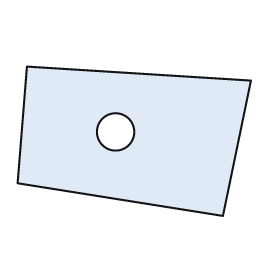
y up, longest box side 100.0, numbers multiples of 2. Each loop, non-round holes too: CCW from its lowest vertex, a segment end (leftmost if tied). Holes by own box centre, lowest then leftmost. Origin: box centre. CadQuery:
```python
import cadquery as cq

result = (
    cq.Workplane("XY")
    .moveTo(38.0, -32.0)
    .lineTo(50.0, 26.0)
    .lineTo(-46.0, 32.0)
    .lineTo(-50.0, -18.0)
    .close()
    .moveTo(-8.0, 4.0)
    .circle(8.0)
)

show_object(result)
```